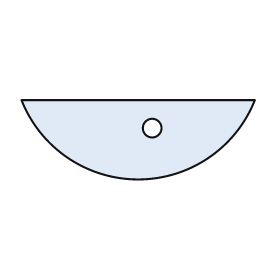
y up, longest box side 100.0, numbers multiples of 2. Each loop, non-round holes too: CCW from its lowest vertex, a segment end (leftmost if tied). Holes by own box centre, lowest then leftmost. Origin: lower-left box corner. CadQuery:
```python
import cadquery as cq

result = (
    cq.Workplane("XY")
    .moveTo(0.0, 34.0)
    .threePointArc((50.0, 0.0), (100.0, 34.0))
    .close()
    .moveTo(56.0, 22.0)
    .circle(4.0)
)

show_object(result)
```